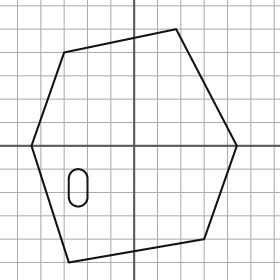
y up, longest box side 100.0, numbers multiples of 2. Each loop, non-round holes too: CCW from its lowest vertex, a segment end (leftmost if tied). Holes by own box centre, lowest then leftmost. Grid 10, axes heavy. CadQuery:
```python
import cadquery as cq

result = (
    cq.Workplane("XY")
    .moveTo(-28.0, -50.0)
    .lineTo(30.0, -40.0)
    .lineTo(44.0, 0.0)
    .lineTo(18.0, 50.0)
    .lineTo(-30.0, 40.0)
    .lineTo(-44.0, 0.0)
    .close()
    .moveTo(-28.0, -22.0)
    .threePointArc((-24.0, -26.0), (-20.0, -22.0))
    .lineTo(-20.0, -14.0)
    .threePointArc((-24.0, -10.0), (-28.0, -14.0))
    .close()
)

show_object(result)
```